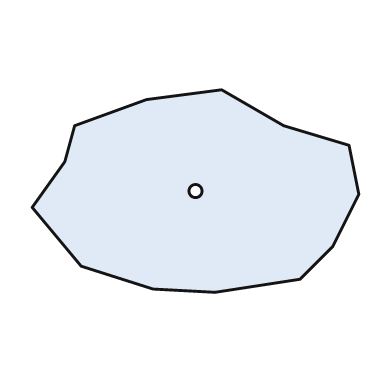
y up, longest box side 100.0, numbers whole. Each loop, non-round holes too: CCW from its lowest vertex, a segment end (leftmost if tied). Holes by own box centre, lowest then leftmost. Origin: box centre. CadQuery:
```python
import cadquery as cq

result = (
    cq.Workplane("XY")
    .moveTo(6.0, -31.0)
    .lineTo(32.0, -27.0)
    .lineTo(42.0, -17.0)
    .lineTo(50.0, -1.0)
    .lineTo(47.0, 14.0)
    .lineTo(27.0, 20.0)
    .lineTo(8.0, 31.0)
    .lineTo(-15.0, 28.0)
    .lineTo(-37.0, 20.0)
    .lineTo(-40.0, 9.0)
    .lineTo(-50.0, -5.0)
    .lineTo(-35.0, -23.0)
    .lineTo(-13.0, -30.0)
    .close()
    .moveTo(0.0, 0.0)
    .circle(2.0)
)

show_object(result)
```